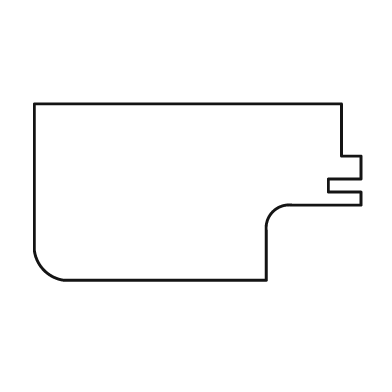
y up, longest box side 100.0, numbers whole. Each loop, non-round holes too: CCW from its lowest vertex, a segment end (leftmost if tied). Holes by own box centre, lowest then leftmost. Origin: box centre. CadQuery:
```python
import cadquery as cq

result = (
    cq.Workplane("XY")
    .moveTo(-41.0, -27.0)
    .lineTo(21.0, -27.0)
    .lineTo(21.0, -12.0)
    .threePointArc((23.0, -6.0), (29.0, -4.0))
    .lineTo(50.0, -4.0)
    .lineTo(50.0, 0.0)
    .lineTo(40.0, 0.0)
    .lineTo(40.0, 4.0)
    .lineTo(50.0, 4.0)
    .lineTo(50.0, 11.0)
    .lineTo(44.0, 11.0)
    .lineTo(44.0, 27.0)
    .lineTo(-50.0, 27.0)
    .lineTo(-50.0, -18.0)
    .threePointArc((-47.0, -24.0), (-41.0, -27.0))
    .close()
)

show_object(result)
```